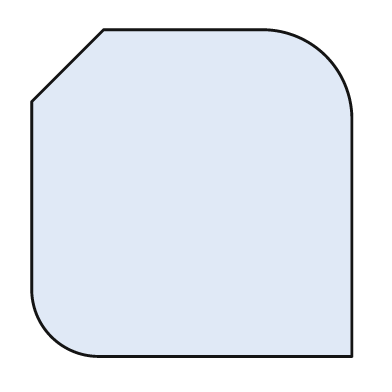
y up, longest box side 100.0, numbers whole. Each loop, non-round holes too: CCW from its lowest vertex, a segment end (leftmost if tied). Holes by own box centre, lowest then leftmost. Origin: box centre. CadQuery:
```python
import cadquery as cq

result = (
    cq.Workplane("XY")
    .moveTo(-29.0, -50.0)
    .lineTo(49.0, -50.0)
    .lineTo(49.0, 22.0)
    .threePointArc((41.0, 42.0), (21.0, 50.0))
    .lineTo(-27.0, 50.0)
    .lineTo(-49.0, 28.0)
    .lineTo(-49.0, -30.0)
    .threePointArc((-43.0, -44.0), (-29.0, -50.0))
    .close()
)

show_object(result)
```